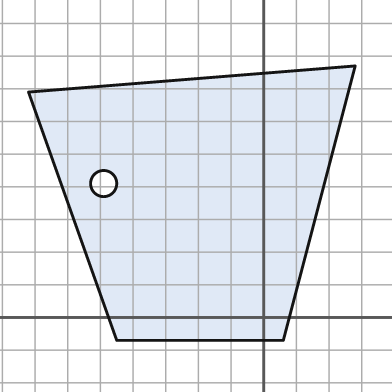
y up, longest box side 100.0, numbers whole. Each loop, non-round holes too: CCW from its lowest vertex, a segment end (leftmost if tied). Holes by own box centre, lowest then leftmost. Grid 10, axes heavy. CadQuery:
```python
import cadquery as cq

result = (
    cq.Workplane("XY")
    .moveTo(-45.0, -7.0)
    .lineTo(6.0, -7.0)
    .lineTo(28.0, 77.0)
    .lineTo(-72.0, 69.0)
    .close()
    .moveTo(-49.0, 41.0)
    .circle(4.0)
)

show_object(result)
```